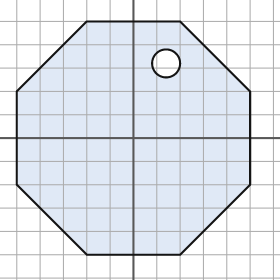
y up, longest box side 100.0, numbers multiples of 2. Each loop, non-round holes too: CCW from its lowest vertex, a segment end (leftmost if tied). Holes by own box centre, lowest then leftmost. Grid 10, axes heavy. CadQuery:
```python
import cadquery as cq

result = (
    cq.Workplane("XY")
    .moveTo(-20.0, -50.0)
    .lineTo(20.0, -50.0)
    .lineTo(50.0, -20.0)
    .lineTo(50.0, 20.0)
    .lineTo(20.0, 50.0)
    .lineTo(-20.0, 50.0)
    .lineTo(-50.0, 20.0)
    .lineTo(-50.0, -20.0)
    .close()
    .moveTo(14.0, 32.0)
    .circle(6.0)
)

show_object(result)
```